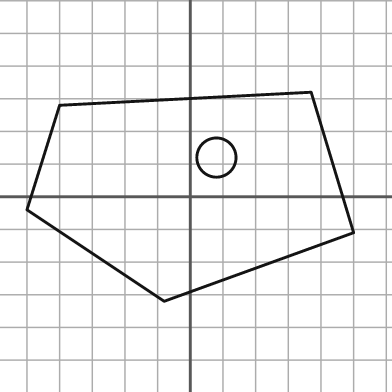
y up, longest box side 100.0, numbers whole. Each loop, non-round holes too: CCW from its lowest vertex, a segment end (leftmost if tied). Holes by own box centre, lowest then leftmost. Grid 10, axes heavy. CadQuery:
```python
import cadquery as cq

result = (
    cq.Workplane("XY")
    .moveTo(-8.0, -32.0)
    .lineTo(50.0, -11.0)
    .lineTo(37.0, 32.0)
    .lineTo(-40.0, 28.0)
    .lineTo(-50.0, -4.0)
    .close()
    .moveTo(8.0, 12.0)
    .circle(6.0)
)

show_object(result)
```